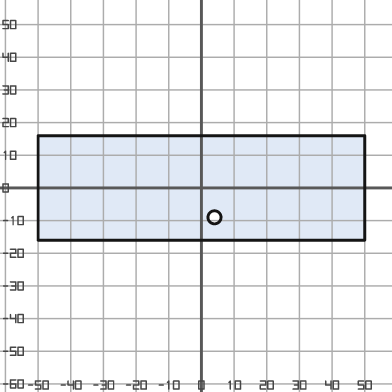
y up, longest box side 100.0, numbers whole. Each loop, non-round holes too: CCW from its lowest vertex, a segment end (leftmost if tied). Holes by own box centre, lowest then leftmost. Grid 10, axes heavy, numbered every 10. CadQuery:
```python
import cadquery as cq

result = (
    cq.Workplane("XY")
    .moveTo(-50.0, -16.0)
    .lineTo(50.0, -16.0)
    .lineTo(50.0, 16.0)
    .lineTo(-50.0, 16.0)
    .close()
    .moveTo(4.0, -9.0)
    .circle(2.0)
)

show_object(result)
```